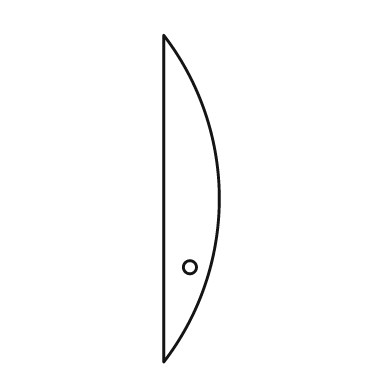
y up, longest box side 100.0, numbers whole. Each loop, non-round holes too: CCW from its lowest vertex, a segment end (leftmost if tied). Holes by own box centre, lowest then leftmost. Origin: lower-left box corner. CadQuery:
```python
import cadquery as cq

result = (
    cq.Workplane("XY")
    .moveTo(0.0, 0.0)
    .threePointArc((17.0, 50.0), (0.0, 100.0))
    .close()
    .moveTo(8.0, 29.0)
    .circle(2.0)
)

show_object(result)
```